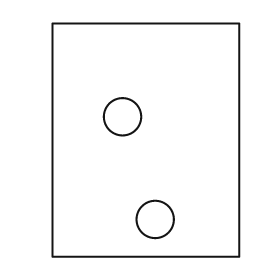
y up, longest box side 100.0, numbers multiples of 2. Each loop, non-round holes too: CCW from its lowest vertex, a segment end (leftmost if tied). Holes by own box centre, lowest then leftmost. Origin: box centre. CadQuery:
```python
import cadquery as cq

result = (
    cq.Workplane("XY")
    .moveTo(-40.0, -50.0)
    .lineTo(40.0, -50.0)
    .lineTo(40.0, 50.0)
    .lineTo(-40.0, 50.0)
    .close()
    .moveTo(4.0, -34.0)
    .circle(8.0)
    .moveTo(-10.0, 10.0)
    .circle(8.0)
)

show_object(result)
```